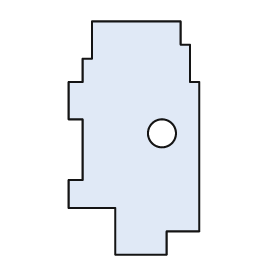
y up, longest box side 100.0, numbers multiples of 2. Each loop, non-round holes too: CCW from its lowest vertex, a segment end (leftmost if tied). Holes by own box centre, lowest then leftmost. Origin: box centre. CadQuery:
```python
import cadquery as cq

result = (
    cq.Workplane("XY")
    .moveTo(-8.0, -50.0)
    .lineTo(14.0, -50.0)
    .lineTo(14.0, -40.0)
    .lineTo(28.0, -40.0)
    .lineTo(28.0, 24.0)
    .lineTo(24.0, 24.0)
    .lineTo(24.0, 40.0)
    .lineTo(20.0, 40.0)
    .lineTo(20.0, 50.0)
    .lineTo(-18.0, 50.0)
    .lineTo(-18.0, 34.0)
    .lineTo(-22.0, 34.0)
    .lineTo(-22.0, 24.0)
    .lineTo(-28.0, 24.0)
    .lineTo(-28.0, 8.0)
    .lineTo(-22.0, 8.0)
    .lineTo(-22.0, -18.0)
    .lineTo(-28.0, -18.0)
    .lineTo(-28.0, -30.0)
    .lineTo(-8.0, -30.0)
    .close()
    .moveTo(12.0, 2.0)
    .circle(6.0)
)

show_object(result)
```